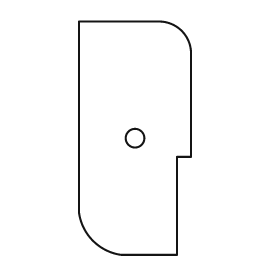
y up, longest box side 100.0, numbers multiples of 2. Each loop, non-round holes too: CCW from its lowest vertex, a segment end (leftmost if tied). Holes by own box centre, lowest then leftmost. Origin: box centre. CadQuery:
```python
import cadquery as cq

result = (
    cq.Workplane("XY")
    .moveTo(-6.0, -50.0)
    .lineTo(18.0, -50.0)
    .lineTo(18.0, -8.0)
    .lineTo(24.0, -8.0)
    .lineTo(24.0, 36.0)
    .threePointArc((20.0, 46.0), (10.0, 50.0))
    .lineTo(-24.0, 50.0)
    .lineTo(-24.0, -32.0)
    .threePointArc((-18.0, -44.0), (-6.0, -50.0))
    .close()
    .moveTo(0.0, 0.0)
    .circle(4.0)
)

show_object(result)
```